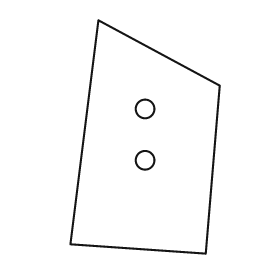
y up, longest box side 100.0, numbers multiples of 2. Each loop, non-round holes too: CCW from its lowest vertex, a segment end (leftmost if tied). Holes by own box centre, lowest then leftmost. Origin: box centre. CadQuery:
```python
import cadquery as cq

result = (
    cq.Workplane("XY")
    .moveTo(26.0, -50.0)
    .lineTo(32.0, 22.0)
    .lineTo(-20.0, 50.0)
    .lineTo(-32.0, -46.0)
    .close()
    .moveTo(0.0, -10.0)
    .circle(4.0)
    .moveTo(0.0, 12.0)
    .circle(4.0)
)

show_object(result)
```